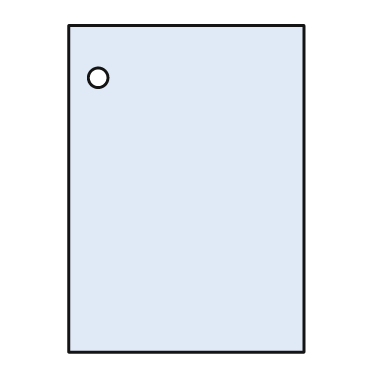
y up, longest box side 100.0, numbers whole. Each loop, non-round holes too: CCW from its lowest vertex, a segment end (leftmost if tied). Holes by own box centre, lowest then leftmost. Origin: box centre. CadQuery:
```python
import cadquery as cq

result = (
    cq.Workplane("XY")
    .moveTo(-36.0, -50.0)
    .lineTo(36.0, -50.0)
    .lineTo(36.0, 50.0)
    .lineTo(-36.0, 50.0)
    .close()
    .moveTo(-27.0, 34.0)
    .circle(3.0)
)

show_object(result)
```